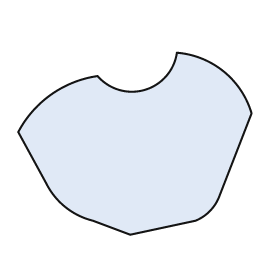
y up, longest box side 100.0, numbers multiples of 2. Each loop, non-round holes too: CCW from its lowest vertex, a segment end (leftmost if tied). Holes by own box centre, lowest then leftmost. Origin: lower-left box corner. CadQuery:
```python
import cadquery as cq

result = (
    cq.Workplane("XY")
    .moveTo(48.0, 0.0)
    .lineTo(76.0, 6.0)
    .threePointArc((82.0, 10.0), (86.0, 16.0))
    .lineTo(100.0, 52.0)
    .threePointArc((88.0, 70.0), (68.0, 78.0))
    .threePointArc((54.0, 62.0), (34.0, 68.0))
    .threePointArc((14.0, 60.0), (0.0, 44.0))
    .lineTo(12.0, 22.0)
    .threePointArc((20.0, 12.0), (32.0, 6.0))
    .close()
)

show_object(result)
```